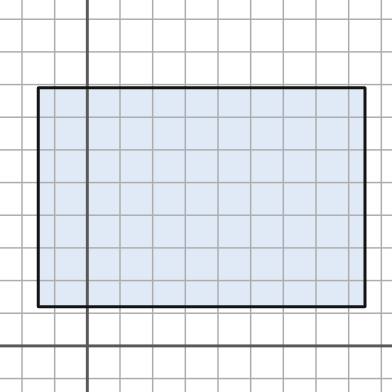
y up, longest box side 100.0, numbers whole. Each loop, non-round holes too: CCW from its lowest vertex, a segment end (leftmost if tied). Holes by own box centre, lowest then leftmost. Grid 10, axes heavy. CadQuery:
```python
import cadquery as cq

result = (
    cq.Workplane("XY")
    .moveTo(-15.0, 12.0)
    .lineTo(85.0, 12.0)
    .lineTo(85.0, 79.0)
    .lineTo(-15.0, 79.0)
    .close()
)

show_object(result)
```